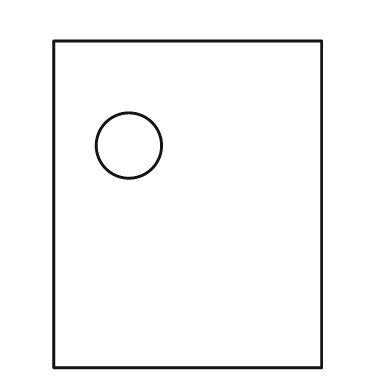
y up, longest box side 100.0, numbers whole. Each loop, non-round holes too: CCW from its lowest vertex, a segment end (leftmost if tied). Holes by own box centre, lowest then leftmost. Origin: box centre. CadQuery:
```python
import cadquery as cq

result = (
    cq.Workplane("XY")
    .moveTo(-41.0, -50.0)
    .lineTo(41.0, -50.0)
    .lineTo(41.0, 50.0)
    .lineTo(-41.0, 50.0)
    .close()
    .moveTo(-18.0, 18.0)
    .circle(10.0)
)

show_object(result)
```